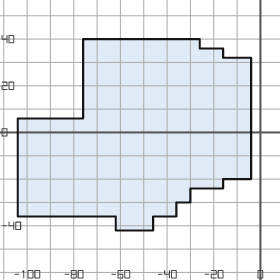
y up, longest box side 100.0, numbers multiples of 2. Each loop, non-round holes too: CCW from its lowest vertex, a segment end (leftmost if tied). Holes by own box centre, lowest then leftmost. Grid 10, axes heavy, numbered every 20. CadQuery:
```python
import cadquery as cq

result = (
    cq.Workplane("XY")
    .moveTo(-62.0, -42.0)
    .lineTo(-46.0, -42.0)
    .lineTo(-46.0, -36.0)
    .lineTo(-36.0, -36.0)
    .lineTo(-36.0, -30.0)
    .lineTo(-30.0, -30.0)
    .lineTo(-30.0, -24.0)
    .lineTo(-16.0, -24.0)
    .lineTo(-16.0, -20.0)
    .lineTo(-4.0, -20.0)
    .lineTo(-4.0, 32.0)
    .lineTo(-16.0, 32.0)
    .lineTo(-16.0, 36.0)
    .lineTo(-26.0, 36.0)
    .lineTo(-26.0, 40.0)
    .lineTo(-76.0, 40.0)
    .lineTo(-76.0, 6.0)
    .lineTo(-104.0, 6.0)
    .lineTo(-104.0, -36.0)
    .lineTo(-62.0, -36.0)
    .close()
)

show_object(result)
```